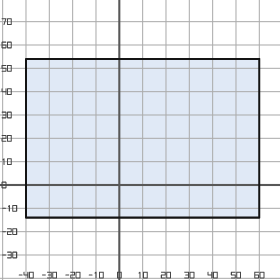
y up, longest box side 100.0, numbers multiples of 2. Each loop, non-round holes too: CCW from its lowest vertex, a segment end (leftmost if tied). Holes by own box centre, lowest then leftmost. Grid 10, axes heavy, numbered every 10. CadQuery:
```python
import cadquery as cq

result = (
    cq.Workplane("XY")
    .moveTo(-40.0, -14.0)
    .lineTo(60.0, -14.0)
    .lineTo(60.0, 54.0)
    .lineTo(-40.0, 54.0)
    .close()
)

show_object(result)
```